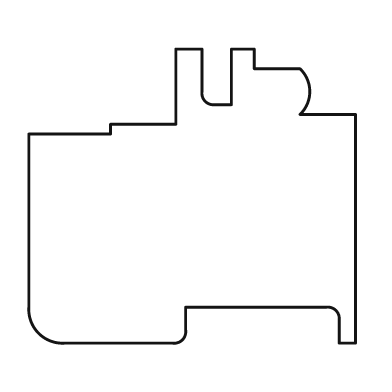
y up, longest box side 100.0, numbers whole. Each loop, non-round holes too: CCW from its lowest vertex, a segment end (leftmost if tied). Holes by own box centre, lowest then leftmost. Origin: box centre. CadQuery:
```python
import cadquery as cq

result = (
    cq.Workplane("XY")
    .moveTo(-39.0, -45.0)
    .lineTo(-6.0, -45.0)
    .threePointArc((-3.0, -44.0), (-2.0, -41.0))
    .lineTo(-2.0, -34.0)
    .lineTo(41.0, -34.0)
    .threePointArc((44.0, -35.0), (45.0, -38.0))
    .lineTo(45.0, -45.0)
    .lineTo(50.0, -45.0)
    .lineTo(50.0, 25.0)
    .lineTo(33.0, 25.0)
    .threePointArc((36.0, 32.0), (33.0, 39.0))
    .lineTo(19.0, 39.0)
    .lineTo(19.0, 45.0)
    .lineTo(12.0, 45.0)
    .lineTo(12.0, 28.0)
    .lineTo(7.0, 28.0)
    .threePointArc((4.0, 29.0), (3.0, 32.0))
    .lineTo(3.0, 45.0)
    .lineTo(-5.0, 45.0)
    .lineTo(-5.0, 22.0)
    .lineTo(-25.0, 22.0)
    .lineTo(-25.0, 19.0)
    .lineTo(-50.0, 19.0)
    .lineTo(-50.0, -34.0)
    .threePointArc((-47.0, -42.0), (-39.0, -45.0))
    .close()
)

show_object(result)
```